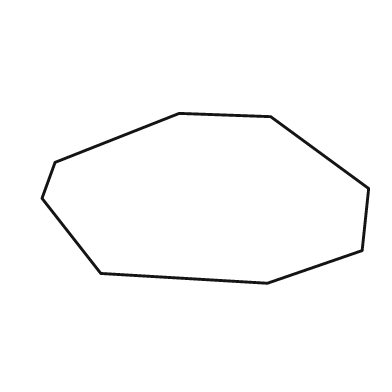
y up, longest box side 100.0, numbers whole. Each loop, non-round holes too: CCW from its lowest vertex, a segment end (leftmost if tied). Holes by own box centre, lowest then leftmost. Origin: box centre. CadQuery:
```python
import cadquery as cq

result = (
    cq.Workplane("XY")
    .moveTo(19.0, -26.0)
    .lineTo(48.0, -16.0)
    .lineTo(50.0, 3.0)
    .lineTo(20.0, 25.0)
    .lineTo(-8.0, 26.0)
    .lineTo(-46.0, 11.0)
    .lineTo(-50.0, 0.0)
    .lineTo(-32.0, -23.0)
    .close()
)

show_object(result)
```